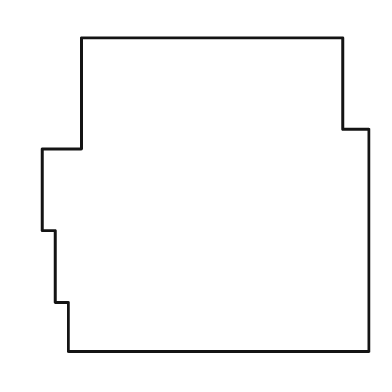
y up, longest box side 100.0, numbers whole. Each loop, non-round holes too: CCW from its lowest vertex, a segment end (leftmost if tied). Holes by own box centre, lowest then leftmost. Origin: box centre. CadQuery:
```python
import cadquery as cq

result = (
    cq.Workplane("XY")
    .moveTo(-42.0, -48.0)
    .lineTo(50.0, -48.0)
    .lineTo(50.0, 20.0)
    .lineTo(42.0, 20.0)
    .lineTo(42.0, 48.0)
    .lineTo(-38.0, 48.0)
    .lineTo(-38.0, 14.0)
    .lineTo(-50.0, 14.0)
    .lineTo(-50.0, -11.0)
    .lineTo(-46.0, -11.0)
    .lineTo(-46.0, -33.0)
    .lineTo(-42.0, -33.0)
    .close()
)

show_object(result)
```